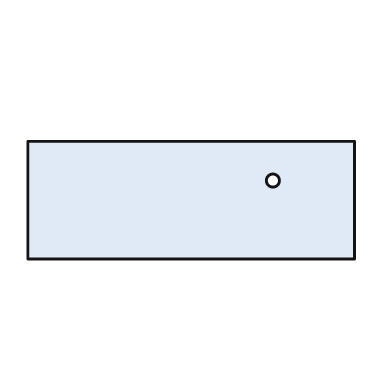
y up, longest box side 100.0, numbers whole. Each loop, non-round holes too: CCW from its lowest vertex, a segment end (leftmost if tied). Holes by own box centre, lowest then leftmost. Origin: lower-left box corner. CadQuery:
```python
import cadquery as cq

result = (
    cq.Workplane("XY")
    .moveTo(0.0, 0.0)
    .lineTo(100.0, 0.0)
    .lineTo(100.0, 36.0)
    .lineTo(0.0, 36.0)
    .close()
    .moveTo(75.0, 24.0)
    .circle(2.0)
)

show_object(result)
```